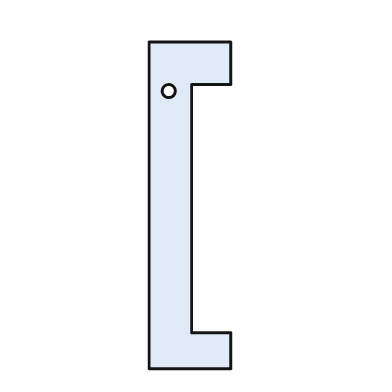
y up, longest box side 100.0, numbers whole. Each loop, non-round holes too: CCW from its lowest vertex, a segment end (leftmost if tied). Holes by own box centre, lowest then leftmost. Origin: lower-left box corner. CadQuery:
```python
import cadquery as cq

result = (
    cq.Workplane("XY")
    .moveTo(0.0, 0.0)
    .lineTo(25.0, 0.0)
    .lineTo(25.0, 11.0)
    .lineTo(13.0, 11.0)
    .lineTo(13.0, 87.0)
    .lineTo(25.0, 87.0)
    .lineTo(25.0, 100.0)
    .lineTo(0.0, 100.0)
    .close()
    .moveTo(6.0, 85.0)
    .circle(2.0)
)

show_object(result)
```